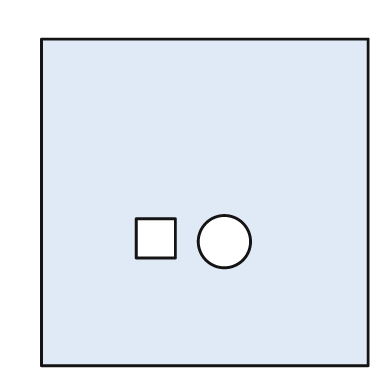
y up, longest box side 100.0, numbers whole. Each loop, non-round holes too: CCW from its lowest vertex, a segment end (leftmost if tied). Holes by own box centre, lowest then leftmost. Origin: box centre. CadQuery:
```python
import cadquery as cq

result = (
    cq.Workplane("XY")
    .moveTo(-50.0, -50.0)
    .lineTo(50.0, -50.0)
    .lineTo(50.0, 50.0)
    .lineTo(-50.0, 50.0)
    .close()
    .moveTo(6.0, -12.0)
    .circle(8.0)
    .moveTo(-21.0, -17.0)
    .lineTo(-9.0, -17.0)
    .lineTo(-9.0, -5.0)
    .lineTo(-21.0, -5.0)
    .close()
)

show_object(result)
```